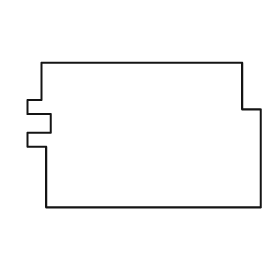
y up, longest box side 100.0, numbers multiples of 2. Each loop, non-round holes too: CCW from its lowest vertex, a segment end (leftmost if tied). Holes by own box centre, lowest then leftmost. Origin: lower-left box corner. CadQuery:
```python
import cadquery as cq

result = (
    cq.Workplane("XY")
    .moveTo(8.0, 0.0)
    .lineTo(100.0, 0.0)
    .lineTo(100.0, 42.0)
    .lineTo(92.0, 42.0)
    .lineTo(92.0, 62.0)
    .lineTo(6.0, 62.0)
    .lineTo(6.0, 46.0)
    .lineTo(0.0, 46.0)
    .lineTo(0.0, 40.0)
    .lineTo(10.0, 40.0)
    .lineTo(10.0, 32.0)
    .lineTo(0.0, 32.0)
    .lineTo(0.0, 26.0)
    .lineTo(8.0, 26.0)
    .close()
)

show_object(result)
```